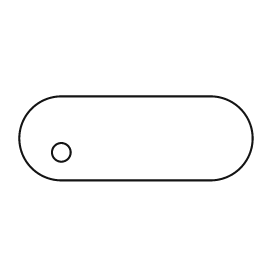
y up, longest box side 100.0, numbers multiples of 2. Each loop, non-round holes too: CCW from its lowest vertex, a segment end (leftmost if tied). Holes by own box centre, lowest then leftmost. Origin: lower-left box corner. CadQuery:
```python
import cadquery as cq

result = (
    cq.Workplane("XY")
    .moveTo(18.0, 0.0)
    .lineTo(82.0, 0.0)
    .threePointArc((100.0, 18.0), (82.0, 36.0))
    .lineTo(18.0, 36.0)
    .threePointArc((0.0, 18.0), (18.0, 0.0))
    .close()
    .moveTo(18.0, 12.0)
    .circle(4.0)
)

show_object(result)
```